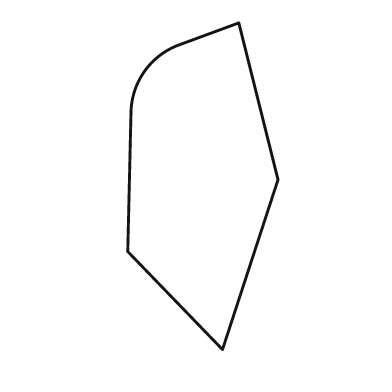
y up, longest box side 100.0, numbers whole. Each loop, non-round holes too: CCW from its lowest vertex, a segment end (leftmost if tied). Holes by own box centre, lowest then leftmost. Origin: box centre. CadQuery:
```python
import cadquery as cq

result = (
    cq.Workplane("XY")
    .moveTo(6.0, -50.0)
    .lineTo(23.0, 2.0)
    .lineTo(11.0, 50.0)
    .lineTo(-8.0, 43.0)
    .threePointArc((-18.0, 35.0), (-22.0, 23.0))
    .lineTo(-23.0, -20.0)
    .close()
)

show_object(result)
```